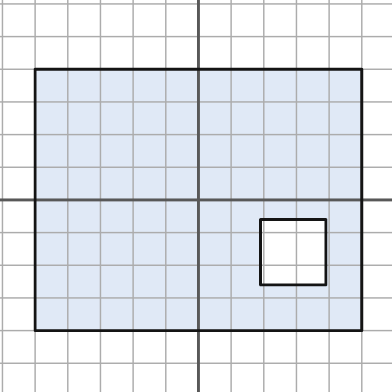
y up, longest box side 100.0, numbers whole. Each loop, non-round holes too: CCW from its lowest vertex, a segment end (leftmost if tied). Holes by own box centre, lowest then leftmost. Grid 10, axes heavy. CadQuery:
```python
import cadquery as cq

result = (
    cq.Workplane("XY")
    .moveTo(-50.0, -40.0)
    .lineTo(50.0, -40.0)
    .lineTo(50.0, 40.0)
    .lineTo(-50.0, 40.0)
    .close()
    .moveTo(19.0, -26.0)
    .lineTo(39.0, -26.0)
    .lineTo(39.0, -6.0)
    .lineTo(19.0, -6.0)
    .close()
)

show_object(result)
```